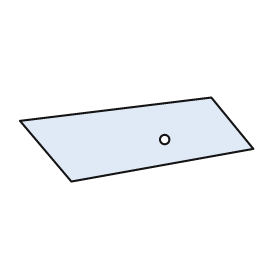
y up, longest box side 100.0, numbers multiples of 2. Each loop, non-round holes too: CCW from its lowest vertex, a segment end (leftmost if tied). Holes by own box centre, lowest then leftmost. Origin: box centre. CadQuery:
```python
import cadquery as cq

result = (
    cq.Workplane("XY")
    .moveTo(-28.0, -18.0)
    .lineTo(50.0, -4.0)
    .lineTo(32.0, 18.0)
    .lineTo(-50.0, 8.0)
    .close()
    .moveTo(12.0, 0.0)
    .circle(2.0)
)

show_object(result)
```